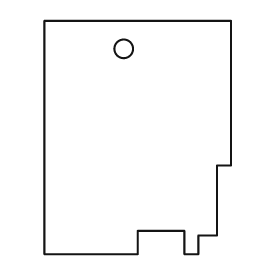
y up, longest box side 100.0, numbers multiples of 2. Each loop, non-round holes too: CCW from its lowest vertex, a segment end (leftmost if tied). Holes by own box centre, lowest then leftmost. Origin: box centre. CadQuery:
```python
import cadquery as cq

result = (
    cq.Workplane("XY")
    .moveTo(-40.0, -50.0)
    .lineTo(0.0, -50.0)
    .lineTo(0.0, -40.0)
    .lineTo(20.0, -40.0)
    .lineTo(20.0, -50.0)
    .lineTo(26.0, -50.0)
    .lineTo(26.0, -42.0)
    .lineTo(34.0, -42.0)
    .lineTo(34.0, -12.0)
    .lineTo(40.0, -12.0)
    .lineTo(40.0, 50.0)
    .lineTo(-40.0, 50.0)
    .close()
    .moveTo(-6.0, 38.0)
    .circle(4.0)
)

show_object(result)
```